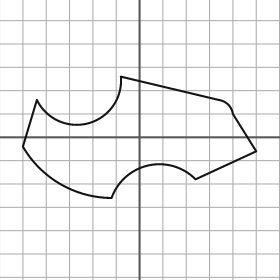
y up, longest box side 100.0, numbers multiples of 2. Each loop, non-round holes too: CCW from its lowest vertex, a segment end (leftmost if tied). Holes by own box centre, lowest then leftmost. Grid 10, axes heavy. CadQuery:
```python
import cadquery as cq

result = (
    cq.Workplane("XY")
    .moveTo(-12.0, -26.0)
    .threePointArc((4.0, -12.0), (24.0, -18.0))
    .lineTo(50.0, -6.0)
    .lineTo(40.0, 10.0)
    .threePointArc((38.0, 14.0), (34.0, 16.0))
    .lineTo(-8.0, 26.0)
    .threePointArc((-22.0, 6.0), (-44.0, 16.0))
    .lineTo(-50.0, -4.0)
    .threePointArc((-34.0, -20.0), (-12.0, -26.0))
    .close()
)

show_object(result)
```